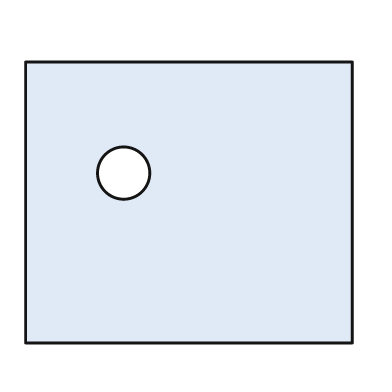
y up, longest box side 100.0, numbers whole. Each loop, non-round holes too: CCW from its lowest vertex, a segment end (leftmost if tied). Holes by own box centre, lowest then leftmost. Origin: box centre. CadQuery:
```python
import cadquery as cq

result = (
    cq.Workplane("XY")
    .moveTo(-50.0, -43.0)
    .lineTo(50.0, -43.0)
    .lineTo(50.0, 43.0)
    .lineTo(-50.0, 43.0)
    .close()
    .moveTo(-20.0, 9.0)
    .circle(8.0)
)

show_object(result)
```